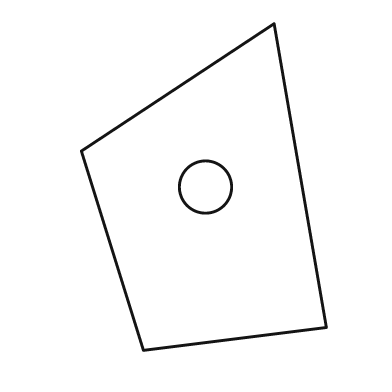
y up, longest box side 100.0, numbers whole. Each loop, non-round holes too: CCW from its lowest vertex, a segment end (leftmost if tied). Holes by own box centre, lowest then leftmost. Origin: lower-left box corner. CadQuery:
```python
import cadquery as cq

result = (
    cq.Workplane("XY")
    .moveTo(19.0, 0.0)
    .lineTo(75.0, 7.0)
    .lineTo(59.0, 100.0)
    .lineTo(0.0, 61.0)
    .close()
    .moveTo(38.0, 50.0)
    .circle(8.0)
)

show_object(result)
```